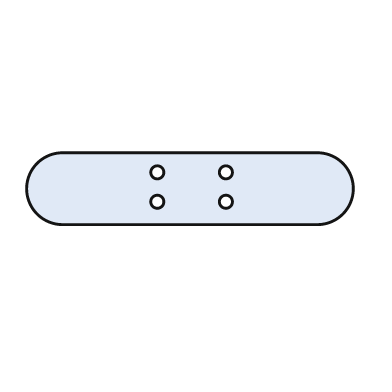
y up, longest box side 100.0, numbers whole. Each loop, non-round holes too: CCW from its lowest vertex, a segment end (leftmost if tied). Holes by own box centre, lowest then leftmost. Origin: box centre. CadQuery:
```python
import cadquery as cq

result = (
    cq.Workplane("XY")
    .moveTo(-39.0, -11.0)
    .lineTo(39.0, -11.0)
    .threePointArc((50.0, 0.0), (39.0, 11.0))
    .lineTo(-39.0, 11.0)
    .threePointArc((-50.0, 0.0), (-39.0, -11.0))
    .close()
    .moveTo(-10.0, -4.0)
    .circle(2.0)
    .moveTo(11.0, -4.0)
    .circle(2.0)
    .moveTo(-10.0, 5.0)
    .circle(2.0)
    .moveTo(11.0, 5.0)
    .circle(2.0)
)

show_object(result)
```